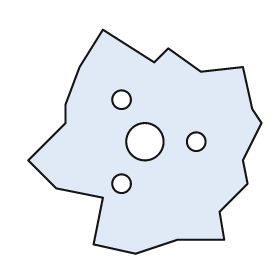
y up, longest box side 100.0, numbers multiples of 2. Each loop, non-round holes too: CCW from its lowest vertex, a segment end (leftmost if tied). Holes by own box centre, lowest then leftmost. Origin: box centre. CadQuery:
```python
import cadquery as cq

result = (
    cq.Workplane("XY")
    .moveTo(-4.0, -48.0)
    .lineTo(14.0, -42.0)
    .lineTo(34.0, -42.0)
    .lineTo(32.0, -30.0)
    .lineTo(44.0, -18.0)
    .lineTo(42.0, -8.0)
    .lineTo(50.0, 8.0)
    .lineTo(46.0, 14.0)
    .lineTo(42.0, 32.0)
    .lineTo(24.0, 30.0)
    .lineTo(10.0, 40.0)
    .lineTo(4.0, 34.0)
    .lineTo(-18.0, 48.0)
    .lineTo(-28.0, 32.0)
    .lineTo(-34.0, 16.0)
    .lineTo(-34.0, 8.0)
    .lineTo(-50.0, -8.0)
    .lineTo(-38.0, -20.0)
    .lineTo(-18.0, -24.0)
    .lineTo(-22.0, -44.0)
    .close()
    .moveTo(-10.0, -18.0)
    .circle(4.0)
    .moveTo(0.0, 0.0)
    .circle(8.0)
    .moveTo(22.0, 0.0)
    .circle(4.0)
    .moveTo(-10.0, 18.0)
    .circle(4.0)
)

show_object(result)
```